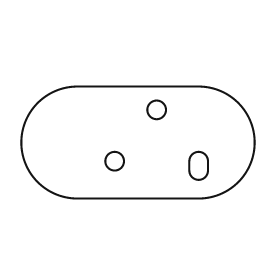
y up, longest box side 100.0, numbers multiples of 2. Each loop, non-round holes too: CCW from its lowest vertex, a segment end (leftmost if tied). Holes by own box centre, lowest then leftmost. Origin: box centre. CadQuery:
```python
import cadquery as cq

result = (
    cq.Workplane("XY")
    .moveTo(-26.0, -24.0)
    .lineTo(26.0, -24.0)
    .threePointArc((50.0, 0.0), (26.0, 24.0))
    .lineTo(-26.0, 24.0)
    .threePointArc((-50.0, 0.0), (-26.0, -24.0))
    .close()
    .moveTo(22.0, -12.0)
    .threePointArc((26.0, -16.0), (30.0, -12.0))
    .lineTo(30.0, -8.0)
    .threePointArc((26.0, -4.0), (22.0, -8.0))
    .close()
    .moveTo(-10.0, -8.0)
    .circle(4.0)
    .moveTo(8.0, 14.0)
    .circle(4.0)
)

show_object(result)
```